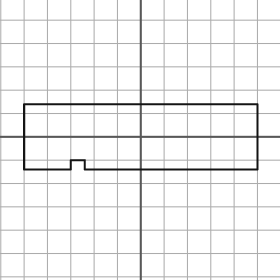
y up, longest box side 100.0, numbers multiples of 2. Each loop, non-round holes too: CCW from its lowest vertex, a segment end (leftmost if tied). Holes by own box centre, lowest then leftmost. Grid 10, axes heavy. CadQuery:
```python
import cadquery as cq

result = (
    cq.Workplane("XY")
    .moveTo(-50.0, -14.0)
    .lineTo(-30.0, -14.0)
    .lineTo(-30.0, -10.0)
    .lineTo(-24.0, -10.0)
    .lineTo(-24.0, -14.0)
    .lineTo(50.0, -14.0)
    .lineTo(50.0, 14.0)
    .lineTo(-50.0, 14.0)
    .close()
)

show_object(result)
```